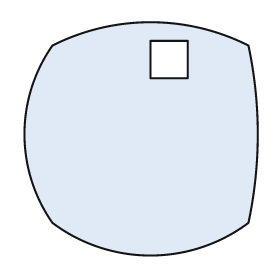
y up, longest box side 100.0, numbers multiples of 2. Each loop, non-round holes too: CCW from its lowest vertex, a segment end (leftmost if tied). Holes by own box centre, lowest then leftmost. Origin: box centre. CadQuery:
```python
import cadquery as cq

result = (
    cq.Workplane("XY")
    .moveTo(-38.0, -36.0)
    .threePointArc((4.0, -50.0), (46.0, -36.0))
    .threePointArc((50.0, 2.0), (46.0, 40.0))
    .threePointArc((4.0, 50.0), (-38.0, 40.0))
    .threePointArc((-50.0, 2.0), (-38.0, -36.0))
    .close()
    .moveTo(4.0, 26.0)
    .lineTo(20.0, 26.0)
    .lineTo(20.0, 42.0)
    .lineTo(4.0, 42.0)
    .close()
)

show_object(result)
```